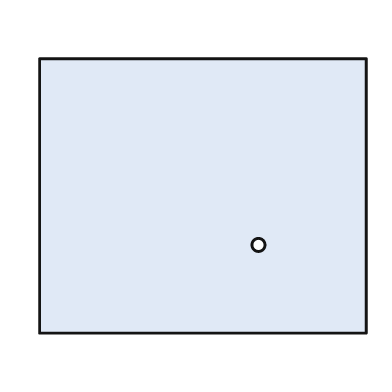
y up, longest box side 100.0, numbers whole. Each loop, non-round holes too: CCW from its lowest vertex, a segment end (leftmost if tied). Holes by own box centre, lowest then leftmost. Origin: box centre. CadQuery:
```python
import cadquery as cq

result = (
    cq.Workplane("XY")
    .moveTo(-50.0, -42.0)
    .lineTo(50.0, -42.0)
    .lineTo(50.0, 42.0)
    .lineTo(-50.0, 42.0)
    .close()
    .moveTo(17.0, -15.0)
    .circle(2.0)
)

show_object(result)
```